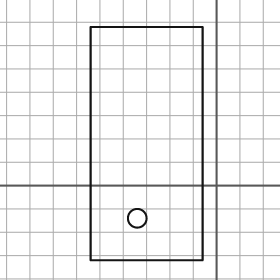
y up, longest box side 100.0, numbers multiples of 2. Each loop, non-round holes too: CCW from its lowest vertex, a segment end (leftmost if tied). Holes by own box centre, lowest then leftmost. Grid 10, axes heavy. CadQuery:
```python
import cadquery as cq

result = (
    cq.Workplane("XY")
    .moveTo(-54.0, -32.0)
    .lineTo(-6.0, -32.0)
    .lineTo(-6.0, 68.0)
    .lineTo(-54.0, 68.0)
    .close()
    .moveTo(-34.0, -14.0)
    .circle(4.0)
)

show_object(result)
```